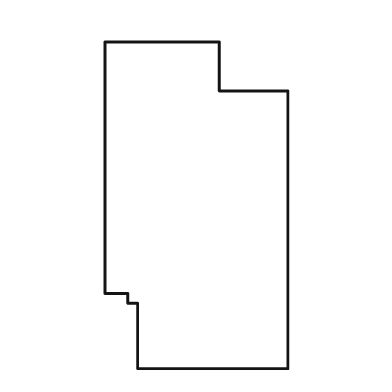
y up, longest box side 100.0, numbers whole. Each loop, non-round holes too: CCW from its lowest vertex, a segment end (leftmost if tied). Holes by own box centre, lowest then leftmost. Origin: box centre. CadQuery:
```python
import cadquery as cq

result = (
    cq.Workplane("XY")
    .moveTo(-18.0, -50.0)
    .lineTo(28.0, -50.0)
    .lineTo(28.0, 35.0)
    .lineTo(7.0, 35.0)
    .lineTo(7.0, 50.0)
    .lineTo(-28.0, 50.0)
    .lineTo(-28.0, -27.0)
    .lineTo(-21.0, -27.0)
    .lineTo(-21.0, -30.0)
    .lineTo(-18.0, -30.0)
    .close()
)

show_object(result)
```